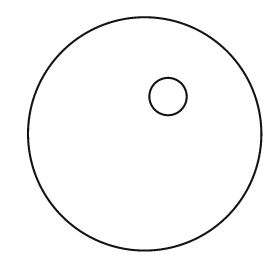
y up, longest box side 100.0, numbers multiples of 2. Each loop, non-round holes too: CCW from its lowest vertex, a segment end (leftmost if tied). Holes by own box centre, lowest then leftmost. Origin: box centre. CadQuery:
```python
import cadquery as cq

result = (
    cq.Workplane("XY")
    .moveTo(0.0, 0.0)
    .circle(50.0)
    .moveTo(10.0, 16.0)
    .circle(8.0)
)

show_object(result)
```